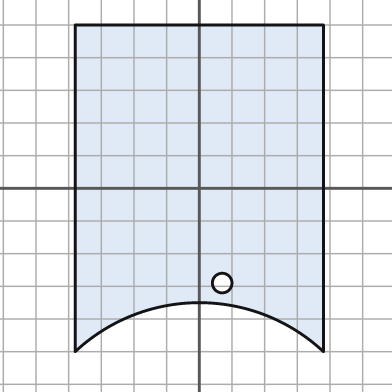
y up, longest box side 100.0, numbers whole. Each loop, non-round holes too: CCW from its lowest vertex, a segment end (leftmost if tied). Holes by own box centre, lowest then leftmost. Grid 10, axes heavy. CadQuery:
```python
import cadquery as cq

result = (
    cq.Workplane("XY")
    .moveTo(-38.0, -50.0)
    .threePointArc((0.0, -35.0), (38.0, -50.0))
    .lineTo(38.0, 50.0)
    .lineTo(-38.0, 50.0)
    .close()
    .moveTo(7.0, -29.0)
    .circle(3.0)
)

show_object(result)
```